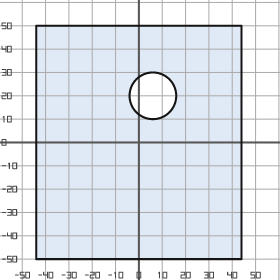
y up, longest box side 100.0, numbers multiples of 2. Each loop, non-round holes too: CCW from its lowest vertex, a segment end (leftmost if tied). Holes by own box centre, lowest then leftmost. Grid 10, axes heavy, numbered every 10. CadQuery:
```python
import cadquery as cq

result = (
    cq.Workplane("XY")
    .moveTo(-44.0, -50.0)
    .lineTo(44.0, -50.0)
    .lineTo(44.0, 50.0)
    .lineTo(-44.0, 50.0)
    .close()
    .moveTo(6.0, 20.0)
    .circle(10.0)
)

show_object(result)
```